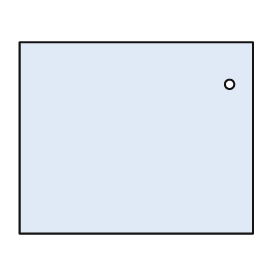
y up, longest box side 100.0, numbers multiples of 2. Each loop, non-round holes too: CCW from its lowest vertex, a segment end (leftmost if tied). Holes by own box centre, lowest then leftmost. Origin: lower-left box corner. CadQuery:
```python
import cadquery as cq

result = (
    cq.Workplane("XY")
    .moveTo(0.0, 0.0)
    .lineTo(100.0, 0.0)
    .lineTo(100.0, 82.0)
    .lineTo(0.0, 82.0)
    .close()
    .moveTo(90.0, 64.0)
    .circle(2.0)
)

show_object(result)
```